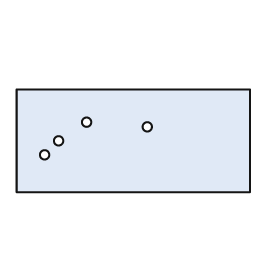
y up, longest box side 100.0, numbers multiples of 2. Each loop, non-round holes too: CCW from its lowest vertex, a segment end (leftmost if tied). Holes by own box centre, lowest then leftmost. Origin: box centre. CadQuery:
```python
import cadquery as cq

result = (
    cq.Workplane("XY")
    .moveTo(-50.0, -22.0)
    .lineTo(50.0, -22.0)
    .lineTo(50.0, 22.0)
    .lineTo(-50.0, 22.0)
    .close()
    .moveTo(-38.0, -6.0)
    .circle(2.0)
    .moveTo(-32.0, 0.0)
    .circle(2.0)
    .moveTo(6.0, 6.0)
    .circle(2.0)
    .moveTo(-20.0, 8.0)
    .circle(2.0)
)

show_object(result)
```